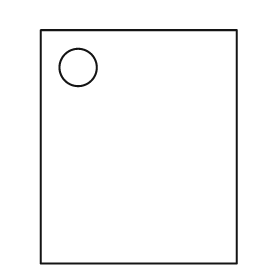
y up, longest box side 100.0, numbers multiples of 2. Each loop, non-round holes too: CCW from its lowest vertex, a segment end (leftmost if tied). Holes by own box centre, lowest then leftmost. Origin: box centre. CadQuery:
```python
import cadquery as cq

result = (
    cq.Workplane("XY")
    .moveTo(-42.0, -50.0)
    .lineTo(42.0, -50.0)
    .lineTo(42.0, 50.0)
    .lineTo(-42.0, 50.0)
    .close()
    .moveTo(-26.0, 34.0)
    .circle(8.0)
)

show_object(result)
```